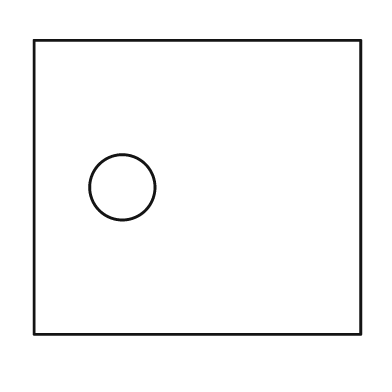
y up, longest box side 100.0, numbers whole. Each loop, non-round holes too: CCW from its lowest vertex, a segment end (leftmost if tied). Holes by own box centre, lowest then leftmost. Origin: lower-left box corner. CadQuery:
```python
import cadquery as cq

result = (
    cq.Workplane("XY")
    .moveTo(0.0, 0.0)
    .lineTo(100.0, 0.0)
    .lineTo(100.0, 90.0)
    .lineTo(0.0, 90.0)
    .close()
    .moveTo(27.0, 45.0)
    .circle(10.0)
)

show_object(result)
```